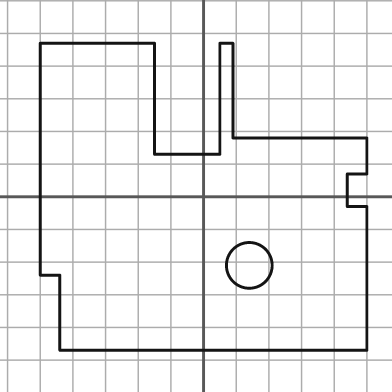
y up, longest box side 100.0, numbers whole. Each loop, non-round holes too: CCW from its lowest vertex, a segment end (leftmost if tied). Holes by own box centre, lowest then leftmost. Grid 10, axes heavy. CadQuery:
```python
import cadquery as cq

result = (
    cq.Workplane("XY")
    .moveTo(-44.0, -47.0)
    .lineTo(50.0, -47.0)
    .lineTo(50.0, -3.0)
    .lineTo(44.0, -3.0)
    .lineTo(44.0, 7.0)
    .lineTo(50.0, 7.0)
    .lineTo(50.0, 18.0)
    .lineTo(9.0, 18.0)
    .lineTo(9.0, 47.0)
    .lineTo(5.0, 47.0)
    .lineTo(5.0, 13.0)
    .lineTo(-15.0, 13.0)
    .lineTo(-15.0, 47.0)
    .lineTo(-50.0, 47.0)
    .lineTo(-50.0, -24.0)
    .lineTo(-44.0, -24.0)
    .close()
    .moveTo(14.0, -21.0)
    .circle(7.0)
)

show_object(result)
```